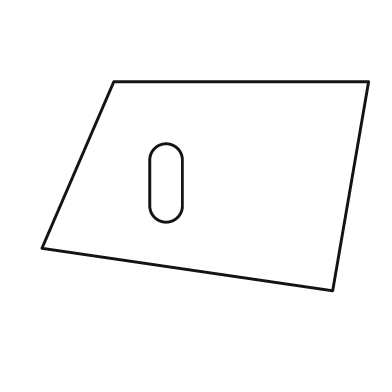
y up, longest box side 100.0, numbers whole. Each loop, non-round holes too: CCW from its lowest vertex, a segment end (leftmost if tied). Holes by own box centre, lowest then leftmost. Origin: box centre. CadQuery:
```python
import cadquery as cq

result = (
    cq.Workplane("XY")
    .moveTo(39.0, -32.0)
    .lineTo(50.0, 32.0)
    .lineTo(-28.0, 32.0)
    .lineTo(-50.0, -19.0)
    .close()
    .moveTo(-17.0, -6.0)
    .threePointArc((-12.0, -11.0), (-7.0, -6.0))
    .lineTo(-7.0, 8.0)
    .threePointArc((-12.0, 13.0), (-17.0, 8.0))
    .close()
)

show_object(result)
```